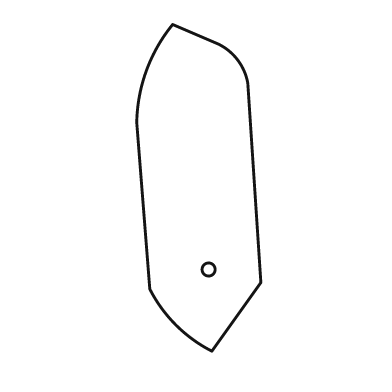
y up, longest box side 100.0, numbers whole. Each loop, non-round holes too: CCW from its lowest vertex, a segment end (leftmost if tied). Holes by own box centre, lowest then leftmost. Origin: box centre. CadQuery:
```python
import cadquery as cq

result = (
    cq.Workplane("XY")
    .moveTo(4.0, -50.0)
    .lineTo(19.0, -29.0)
    .lineTo(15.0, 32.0)
    .threePointArc((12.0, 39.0), (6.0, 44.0))
    .lineTo(-8.0, 50.0)
    .threePointArc((-16.0, 36.0), (-19.0, 20.0))
    .lineTo(-15.0, -31.0)
    .threePointArc((-7.0, -42.0), (4.0, -50.0))
    .close()
    .moveTo(3.0, -25.0)
    .circle(2.0)
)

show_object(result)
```